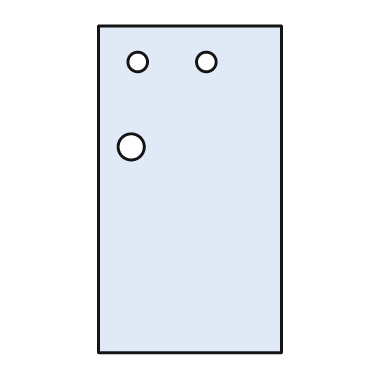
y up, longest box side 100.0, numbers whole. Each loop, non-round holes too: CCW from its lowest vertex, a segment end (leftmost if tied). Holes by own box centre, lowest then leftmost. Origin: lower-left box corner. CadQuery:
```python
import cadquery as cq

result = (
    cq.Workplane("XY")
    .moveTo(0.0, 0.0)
    .lineTo(56.0, 0.0)
    .lineTo(56.0, 100.0)
    .lineTo(0.0, 100.0)
    .close()
    .moveTo(10.0, 63.0)
    .circle(4.0)
    .moveTo(12.0, 89.0)
    .circle(3.0)
    .moveTo(33.0, 89.0)
    .circle(3.0)
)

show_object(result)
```